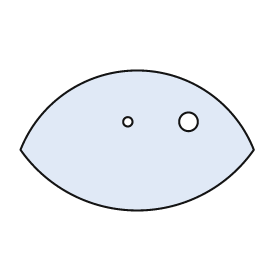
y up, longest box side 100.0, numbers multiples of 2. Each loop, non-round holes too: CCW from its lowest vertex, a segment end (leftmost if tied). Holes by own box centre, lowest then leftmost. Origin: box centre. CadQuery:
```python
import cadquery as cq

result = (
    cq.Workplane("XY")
    .moveTo(-50.0, -4.0)
    .threePointArc((0.0, -30.0), (50.0, -4.0))
    .threePointArc((0.0, 30.0), (-50.0, -4.0))
    .close()
    .moveTo(-4.0, 8.0)
    .circle(2.0)
    .moveTo(22.0, 8.0)
    .circle(4.0)
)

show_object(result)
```